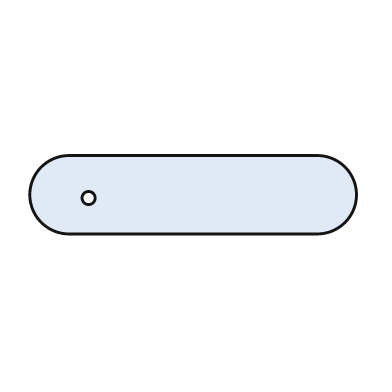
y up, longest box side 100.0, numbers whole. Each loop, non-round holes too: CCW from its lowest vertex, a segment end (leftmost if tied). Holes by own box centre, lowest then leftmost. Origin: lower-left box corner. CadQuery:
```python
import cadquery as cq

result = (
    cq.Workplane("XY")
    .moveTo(12.0, 0.0)
    .lineTo(88.0, 0.0)
    .threePointArc((100.0, 12.0), (88.0, 24.0))
    .lineTo(12.0, 24.0)
    .threePointArc((0.0, 12.0), (12.0, 0.0))
    .close()
    .moveTo(18.0, 11.0)
    .circle(2.0)
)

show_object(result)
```